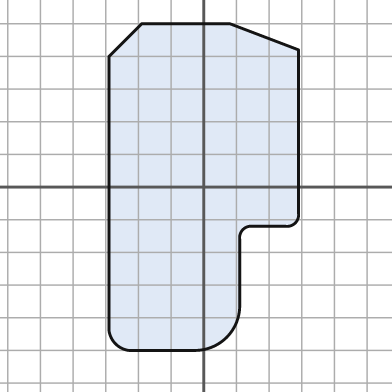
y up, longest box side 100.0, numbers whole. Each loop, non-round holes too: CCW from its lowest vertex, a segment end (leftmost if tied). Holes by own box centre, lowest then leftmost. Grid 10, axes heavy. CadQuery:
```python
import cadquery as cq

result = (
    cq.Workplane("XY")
    .moveTo(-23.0, -50.0)
    .lineTo(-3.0, -50.0)
    .threePointArc((7.0, -46.0), (11.0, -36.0))
    .lineTo(11.0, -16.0)
    .threePointArc((12.0, -13.0), (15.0, -12.0))
    .lineTo(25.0, -12.0)
    .threePointArc((28.0, -11.0), (29.0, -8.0))
    .lineTo(29.0, 42.0)
    .lineTo(8.0, 50.0)
    .lineTo(-19.0, 50.0)
    .lineTo(-29.0, 40.0)
    .lineTo(-29.0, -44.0)
    .threePointArc((-27.0, -48.0), (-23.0, -50.0))
    .close()
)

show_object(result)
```